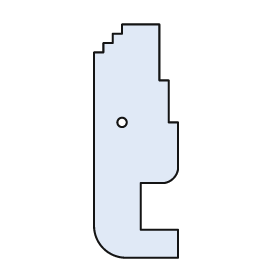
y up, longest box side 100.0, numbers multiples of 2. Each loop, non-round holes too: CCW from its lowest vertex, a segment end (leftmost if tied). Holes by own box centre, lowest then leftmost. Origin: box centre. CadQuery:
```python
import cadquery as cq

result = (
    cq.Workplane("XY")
    .moveTo(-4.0, -50.0)
    .lineTo(18.0, -50.0)
    .lineTo(18.0, -38.0)
    .lineTo(2.0, -38.0)
    .lineTo(2.0, -18.0)
    .lineTo(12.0, -18.0)
    .threePointArc((16.0, -16.0), (18.0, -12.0))
    .lineTo(18.0, 8.0)
    .lineTo(14.0, 8.0)
    .lineTo(14.0, 26.0)
    .lineTo(10.0, 26.0)
    .lineTo(10.0, 50.0)
    .lineTo(-6.0, 50.0)
    .lineTo(-6.0, 46.0)
    .lineTo(-10.0, 46.0)
    .lineTo(-10.0, 42.0)
    .lineTo(-14.0, 42.0)
    .lineTo(-14.0, 38.0)
    .lineTo(-18.0, 38.0)
    .lineTo(-18.0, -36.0)
    .threePointArc((-14.0, -46.0), (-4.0, -50.0))
    .close()
    .moveTo(-6.0, 8.0)
    .circle(2.0)
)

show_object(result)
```